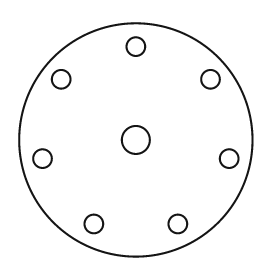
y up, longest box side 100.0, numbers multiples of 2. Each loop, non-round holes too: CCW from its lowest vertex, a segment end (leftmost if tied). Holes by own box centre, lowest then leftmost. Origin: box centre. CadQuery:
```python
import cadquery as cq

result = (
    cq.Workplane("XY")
    .moveTo(0.0, 0.0)
    .circle(50.0)
    .moveTo(-18.0, -36.0)
    .circle(4.0)
    .moveTo(18.0, -36.0)
    .circle(4.0)
    .moveTo(-40.0, -8.0)
    .circle(4.0)
    .moveTo(40.0, -8.0)
    .circle(4.0)
    .moveTo(0.0, 0.0)
    .circle(6.0)
    .moveTo(-32.0, 26.0)
    .circle(4.0)
    .moveTo(32.0, 26.0)
    .circle(4.0)
    .moveTo(0.0, 40.0)
    .circle(4.0)
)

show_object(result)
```